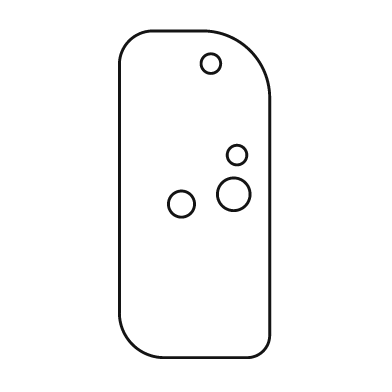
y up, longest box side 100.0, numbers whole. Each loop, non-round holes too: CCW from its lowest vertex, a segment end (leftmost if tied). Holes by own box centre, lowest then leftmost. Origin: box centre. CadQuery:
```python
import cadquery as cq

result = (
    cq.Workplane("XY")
    .moveTo(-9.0, -50.0)
    .lineTo(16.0, -50.0)
    .threePointArc((21.0, -48.0), (23.0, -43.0))
    .lineTo(23.0, 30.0)
    .threePointArc((17.0, 44.0), (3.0, 50.0))
    .lineTo(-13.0, 50.0)
    .threePointArc((-20.0, 47.0), (-23.0, 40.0))
    .lineTo(-23.0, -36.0)
    .threePointArc((-19.0, -46.0), (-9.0, -50.0))
    .close()
    .moveTo(-4.0, -3.0)
    .circle(4.0)
    .moveTo(12.0, 0.0)
    .circle(5.0)
    .moveTo(13.0, 12.0)
    .circle(3.0)
    .moveTo(5.0, 40.0)
    .circle(3.0)
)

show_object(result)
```